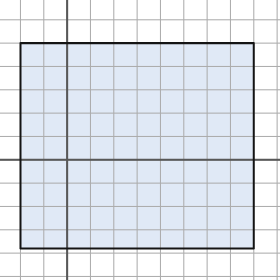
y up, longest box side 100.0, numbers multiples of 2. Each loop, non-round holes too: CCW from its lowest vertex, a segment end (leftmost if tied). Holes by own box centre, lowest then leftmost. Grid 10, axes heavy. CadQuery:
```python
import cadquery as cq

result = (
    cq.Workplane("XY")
    .moveTo(-20.0, -38.0)
    .lineTo(80.0, -38.0)
    .lineTo(80.0, 50.0)
    .lineTo(-20.0, 50.0)
    .close()
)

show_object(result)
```